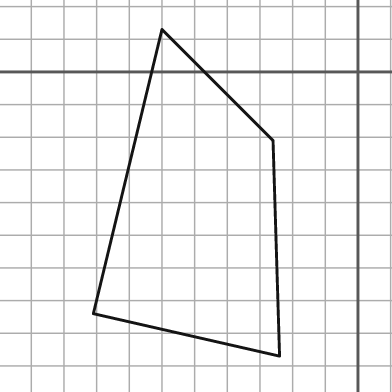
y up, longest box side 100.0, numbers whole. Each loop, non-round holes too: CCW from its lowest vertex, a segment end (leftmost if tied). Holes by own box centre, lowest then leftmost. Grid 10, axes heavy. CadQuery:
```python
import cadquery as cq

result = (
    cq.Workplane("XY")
    .moveTo(-24.0, -87.0)
    .lineTo(-26.0, -21.0)
    .lineTo(-60.0, 13.0)
    .lineTo(-81.0, -74.0)
    .close()
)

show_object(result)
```